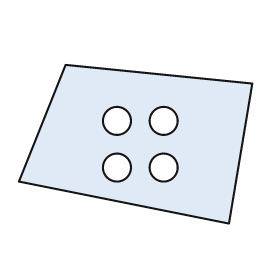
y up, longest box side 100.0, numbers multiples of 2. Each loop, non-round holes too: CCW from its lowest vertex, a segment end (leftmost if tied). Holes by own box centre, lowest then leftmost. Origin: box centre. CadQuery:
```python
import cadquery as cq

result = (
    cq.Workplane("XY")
    .moveTo(40.0, -34.0)
    .lineTo(50.0, 26.0)
    .lineTo(-30.0, 34.0)
    .lineTo(-50.0, -16.0)
    .close()
    .moveTo(-8.0, -10.0)
    .circle(6.0)
    .moveTo(12.0, -10.0)
    .circle(6.0)
    .moveTo(-8.0, 10.0)
    .circle(6.0)
    .moveTo(12.0, 10.0)
    .circle(6.0)
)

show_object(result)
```